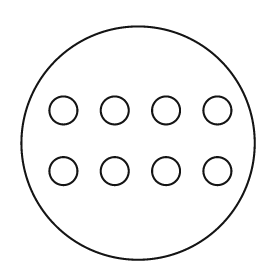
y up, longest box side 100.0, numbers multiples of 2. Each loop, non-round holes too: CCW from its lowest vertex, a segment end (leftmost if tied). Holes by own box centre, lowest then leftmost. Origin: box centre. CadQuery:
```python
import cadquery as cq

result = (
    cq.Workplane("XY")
    .moveTo(0.0, 0.0)
    .circle(50.0)
    .moveTo(-32.0, -12.0)
    .circle(6.0)
    .moveTo(-10.0, -12.0)
    .circle(6.0)
    .moveTo(12.0, -12.0)
    .circle(6.0)
    .moveTo(34.0, -12.0)
    .circle(6.0)
    .moveTo(-32.0, 14.0)
    .circle(6.0)
    .moveTo(-10.0, 14.0)
    .circle(6.0)
    .moveTo(12.0, 14.0)
    .circle(6.0)
    .moveTo(34.0, 14.0)
    .circle(6.0)
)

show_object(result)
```